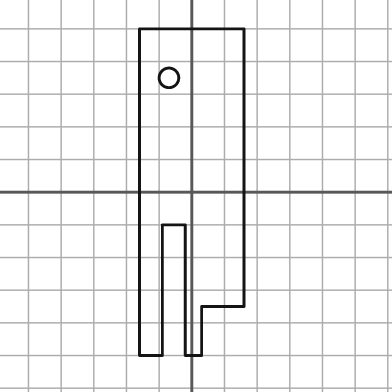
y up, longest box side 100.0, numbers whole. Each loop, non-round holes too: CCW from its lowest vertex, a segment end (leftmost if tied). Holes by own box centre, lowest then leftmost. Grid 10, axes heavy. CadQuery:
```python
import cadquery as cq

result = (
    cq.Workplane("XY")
    .moveTo(-16.0, -50.0)
    .lineTo(-9.0, -50.0)
    .lineTo(-9.0, -10.0)
    .lineTo(-2.0, -10.0)
    .lineTo(-2.0, -50.0)
    .lineTo(3.0, -50.0)
    .lineTo(3.0, -35.0)
    .lineTo(16.0, -35.0)
    .lineTo(16.0, 50.0)
    .lineTo(-16.0, 50.0)
    .close()
    .moveTo(-7.0, 35.0)
    .circle(3.0)
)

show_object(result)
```